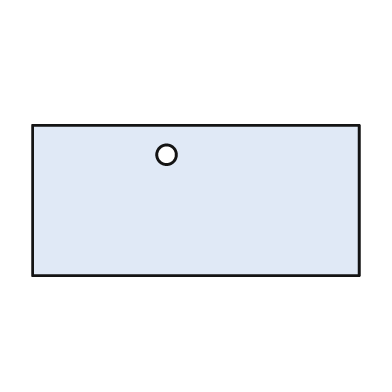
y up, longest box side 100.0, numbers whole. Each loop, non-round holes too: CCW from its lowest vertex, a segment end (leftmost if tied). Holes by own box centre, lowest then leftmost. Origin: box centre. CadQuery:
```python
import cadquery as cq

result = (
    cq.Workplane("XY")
    .moveTo(-50.0, -23.0)
    .lineTo(50.0, -23.0)
    .lineTo(50.0, 23.0)
    .lineTo(-50.0, 23.0)
    .close()
    .moveTo(-9.0, 14.0)
    .circle(3.0)
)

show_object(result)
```